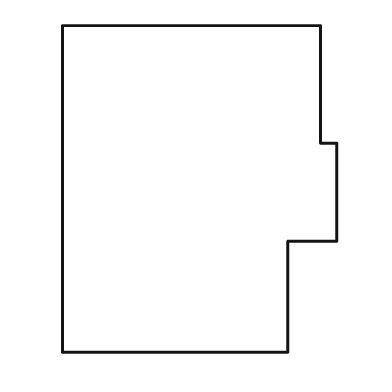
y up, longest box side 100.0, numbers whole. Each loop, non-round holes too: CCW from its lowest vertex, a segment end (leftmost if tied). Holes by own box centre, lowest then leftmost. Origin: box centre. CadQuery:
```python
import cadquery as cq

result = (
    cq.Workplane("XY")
    .moveTo(-42.0, -50.0)
    .lineTo(27.0, -50.0)
    .lineTo(27.0, -16.0)
    .lineTo(42.0, -16.0)
    .lineTo(42.0, 14.0)
    .lineTo(37.0, 14.0)
    .lineTo(37.0, 50.0)
    .lineTo(-42.0, 50.0)
    .close()
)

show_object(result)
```